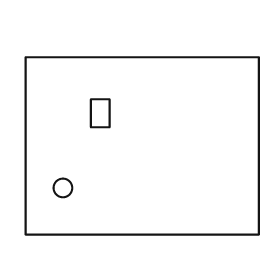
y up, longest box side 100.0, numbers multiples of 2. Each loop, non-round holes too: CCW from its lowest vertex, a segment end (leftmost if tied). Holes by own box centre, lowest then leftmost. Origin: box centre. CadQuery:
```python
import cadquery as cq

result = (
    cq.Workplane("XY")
    .moveTo(-50.0, -38.0)
    .lineTo(50.0, -38.0)
    .lineTo(50.0, 38.0)
    .lineTo(-50.0, 38.0)
    .close()
    .moveTo(-34.0, -18.0)
    .circle(4.0)
    .moveTo(-22.0, 8.0)
    .lineTo(-14.0, 8.0)
    .lineTo(-14.0, 20.0)
    .lineTo(-22.0, 20.0)
    .close()
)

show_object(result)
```